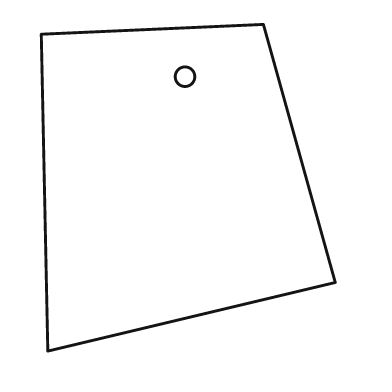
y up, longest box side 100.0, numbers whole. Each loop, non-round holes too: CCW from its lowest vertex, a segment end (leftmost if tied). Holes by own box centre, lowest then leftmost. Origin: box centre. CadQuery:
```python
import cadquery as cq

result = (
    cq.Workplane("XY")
    .moveTo(-43.0, -50.0)
    .lineTo(45.0, -29.0)
    .lineTo(23.0, 50.0)
    .lineTo(-45.0, 47.0)
    .close()
    .moveTo(-1.0, 34.0)
    .circle(3.0)
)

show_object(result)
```